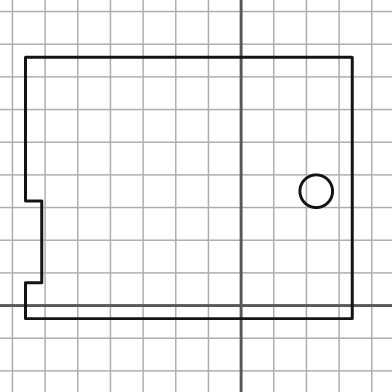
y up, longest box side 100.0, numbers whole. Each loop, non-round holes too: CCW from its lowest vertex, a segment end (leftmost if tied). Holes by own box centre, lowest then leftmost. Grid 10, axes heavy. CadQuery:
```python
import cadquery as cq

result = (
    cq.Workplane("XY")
    .moveTo(-66.0, -4.0)
    .lineTo(34.0, -4.0)
    .lineTo(34.0, 76.0)
    .lineTo(-66.0, 76.0)
    .lineTo(-66.0, 32.0)
    .lineTo(-61.0, 32.0)
    .lineTo(-61.0, 7.0)
    .lineTo(-66.0, 7.0)
    .close()
    .moveTo(23.0, 35.0)
    .circle(5.0)
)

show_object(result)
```